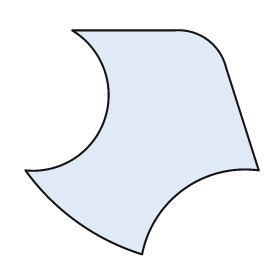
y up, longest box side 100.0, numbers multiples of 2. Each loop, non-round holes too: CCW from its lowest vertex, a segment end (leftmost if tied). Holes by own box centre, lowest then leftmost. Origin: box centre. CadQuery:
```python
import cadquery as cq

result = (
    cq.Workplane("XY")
    .moveTo(0.0, -48.0)
    .threePointArc((18.0, -20.0), (50.0, -12.0))
    .lineTo(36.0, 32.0)
    .threePointArc((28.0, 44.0), (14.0, 48.0))
    .lineTo(-30.0, 48.0)
    .threePointArc((-16.0, 10.0), (-50.0, -12.0))
    .threePointArc((-28.0, -34.0), (0.0, -48.0))
    .close()
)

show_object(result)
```